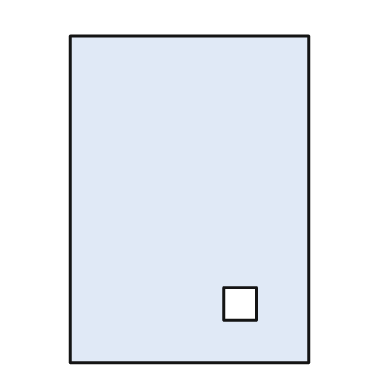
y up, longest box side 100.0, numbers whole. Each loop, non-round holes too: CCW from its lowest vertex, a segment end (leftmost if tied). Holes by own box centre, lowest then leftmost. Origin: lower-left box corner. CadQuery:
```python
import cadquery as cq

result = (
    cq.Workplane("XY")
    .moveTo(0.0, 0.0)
    .lineTo(73.0, 0.0)
    .lineTo(73.0, 100.0)
    .lineTo(0.0, 100.0)
    .close()
    .moveTo(47.0, 13.0)
    .lineTo(57.0, 13.0)
    .lineTo(57.0, 23.0)
    .lineTo(47.0, 23.0)
    .close()
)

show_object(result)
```